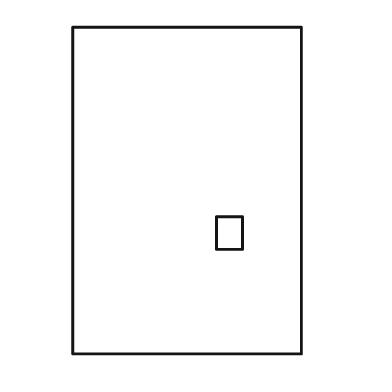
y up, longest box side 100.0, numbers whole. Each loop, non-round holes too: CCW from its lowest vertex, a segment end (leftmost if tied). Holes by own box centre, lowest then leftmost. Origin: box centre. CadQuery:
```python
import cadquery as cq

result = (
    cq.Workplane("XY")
    .moveTo(-35.0, -50.0)
    .lineTo(35.0, -50.0)
    .lineTo(35.0, 50.0)
    .lineTo(-35.0, 50.0)
    .close()
    .moveTo(9.0, -18.0)
    .lineTo(17.0, -18.0)
    .lineTo(17.0, -8.0)
    .lineTo(9.0, -8.0)
    .close()
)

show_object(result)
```